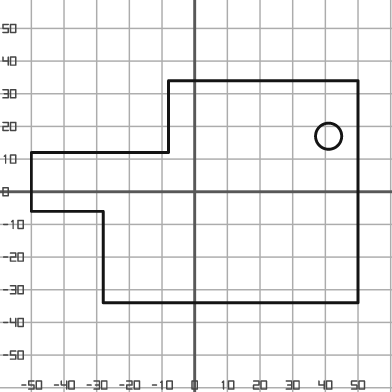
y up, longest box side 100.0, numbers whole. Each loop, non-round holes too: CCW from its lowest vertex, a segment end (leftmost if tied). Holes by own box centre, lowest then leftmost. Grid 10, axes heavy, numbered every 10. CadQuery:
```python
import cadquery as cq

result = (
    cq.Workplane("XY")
    .moveTo(-28.0, -34.0)
    .lineTo(50.0, -34.0)
    .lineTo(50.0, 34.0)
    .lineTo(-8.0, 34.0)
    .lineTo(-8.0, 12.0)
    .lineTo(-50.0, 12.0)
    .lineTo(-50.0, -6.0)
    .lineTo(-28.0, -6.0)
    .close()
    .moveTo(41.0, 17.0)
    .circle(4.0)
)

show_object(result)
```